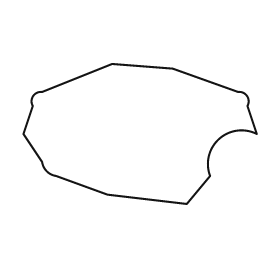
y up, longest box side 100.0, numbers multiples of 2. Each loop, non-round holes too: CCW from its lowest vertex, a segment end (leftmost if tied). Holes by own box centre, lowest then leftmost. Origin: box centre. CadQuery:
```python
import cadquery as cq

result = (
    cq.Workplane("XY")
    .moveTo(20.0, -30.0)
    .lineTo(30.0, -18.0)
    .threePointArc((34.0, -2.0), (50.0, 0.0))
    .lineTo(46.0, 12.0)
    .threePointArc((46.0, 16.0), (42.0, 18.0))
    .lineTo(14.0, 28.0)
    .lineTo(-12.0, 30.0)
    .lineTo(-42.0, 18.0)
    .threePointArc((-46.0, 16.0), (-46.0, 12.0))
    .lineTo(-50.0, 0.0)
    .lineTo(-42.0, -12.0)
    .threePointArc((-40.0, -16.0), (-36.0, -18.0))
    .lineTo(-14.0, -26.0)
    .close()
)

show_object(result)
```